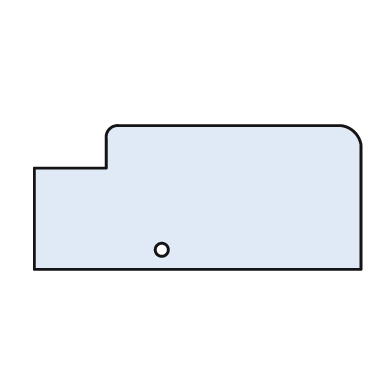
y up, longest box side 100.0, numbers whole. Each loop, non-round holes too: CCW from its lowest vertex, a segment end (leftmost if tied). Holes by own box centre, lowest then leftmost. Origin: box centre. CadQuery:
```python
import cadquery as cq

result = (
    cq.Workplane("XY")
    .moveTo(-50.0, -22.0)
    .lineTo(50.0, -22.0)
    .lineTo(50.0, 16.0)
    .threePointArc((48.0, 20.0), (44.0, 22.0))
    .lineTo(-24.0, 22.0)
    .threePointArc((-27.0, 21.0), (-28.0, 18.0))
    .lineTo(-28.0, 9.0)
    .lineTo(-50.0, 9.0)
    .close()
    .moveTo(-11.0, -16.0)
    .circle(2.0)
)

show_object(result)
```